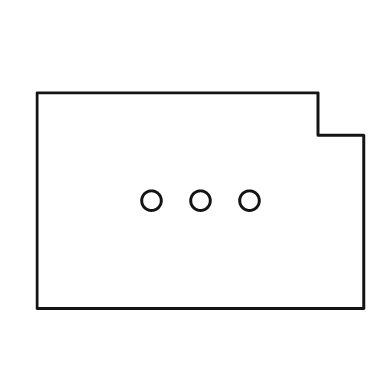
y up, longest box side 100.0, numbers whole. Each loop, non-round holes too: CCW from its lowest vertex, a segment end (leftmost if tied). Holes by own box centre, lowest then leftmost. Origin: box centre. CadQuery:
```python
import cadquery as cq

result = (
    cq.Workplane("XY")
    .moveTo(-50.0, -33.0)
    .lineTo(50.0, -33.0)
    .lineTo(50.0, 20.0)
    .lineTo(36.0, 20.0)
    .lineTo(36.0, 33.0)
    .lineTo(-50.0, 33.0)
    .close()
    .moveTo(-15.0, 0.0)
    .circle(3.0)
    .moveTo(0.0, 0.0)
    .circle(3.0)
    .moveTo(15.0, 0.0)
    .circle(3.0)
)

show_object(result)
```